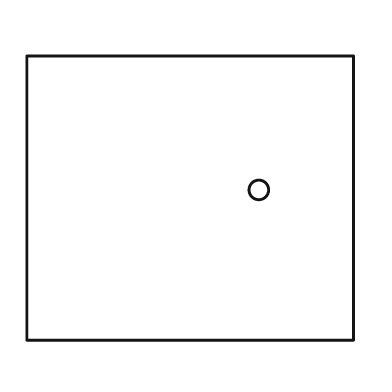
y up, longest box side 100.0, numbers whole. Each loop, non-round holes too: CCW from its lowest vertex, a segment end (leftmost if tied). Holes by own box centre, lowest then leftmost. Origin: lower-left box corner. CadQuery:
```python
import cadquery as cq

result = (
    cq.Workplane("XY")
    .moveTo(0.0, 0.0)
    .lineTo(100.0, 0.0)
    .lineTo(100.0, 87.0)
    .lineTo(0.0, 87.0)
    .close()
    .moveTo(71.0, 46.0)
    .circle(3.0)
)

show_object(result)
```